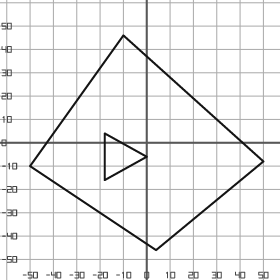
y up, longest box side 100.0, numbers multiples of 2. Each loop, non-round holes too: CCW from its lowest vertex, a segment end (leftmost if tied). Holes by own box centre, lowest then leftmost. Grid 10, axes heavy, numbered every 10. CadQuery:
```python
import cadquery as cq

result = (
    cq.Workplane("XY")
    .moveTo(4.0, -46.0)
    .lineTo(50.0, -8.0)
    .lineTo(-10.0, 46.0)
    .lineTo(-50.0, -10.0)
    .close()
    .moveTo(-18.0, -16.0)
    .lineTo(0.0, -6.0)
    .lineTo(-18.0, 4.0)
    .close()
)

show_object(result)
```